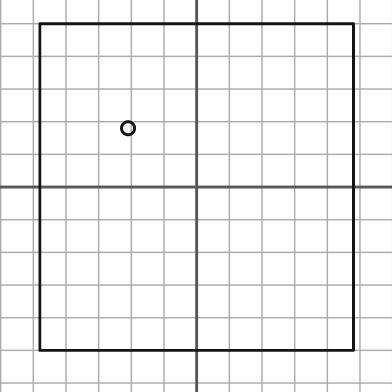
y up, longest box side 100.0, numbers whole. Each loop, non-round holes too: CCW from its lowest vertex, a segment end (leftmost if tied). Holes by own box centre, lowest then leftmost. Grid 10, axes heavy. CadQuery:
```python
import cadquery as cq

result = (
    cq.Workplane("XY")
    .moveTo(-48.0, -50.0)
    .lineTo(48.0, -50.0)
    .lineTo(48.0, 50.0)
    .lineTo(-48.0, 50.0)
    .close()
    .moveTo(-21.0, 18.0)
    .circle(2.0)
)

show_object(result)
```